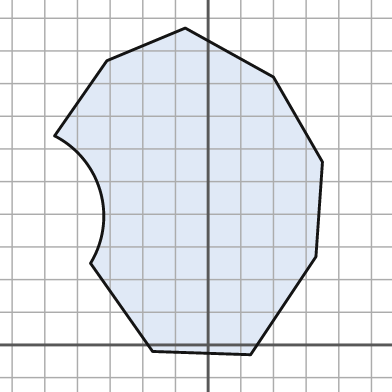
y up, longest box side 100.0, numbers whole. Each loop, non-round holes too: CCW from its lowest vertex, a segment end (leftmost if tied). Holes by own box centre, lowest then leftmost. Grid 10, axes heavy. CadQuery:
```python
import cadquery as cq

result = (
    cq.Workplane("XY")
    .moveTo(13.0, -3.0)
    .lineTo(33.0, 27.0)
    .lineTo(35.0, 56.0)
    .lineTo(20.0, 82.0)
    .lineTo(-7.0, 97.0)
    .lineTo(-31.0, 87.0)
    .lineTo(-47.0, 64.0)
    .threePointArc((-33.0, 47.0), (-36.0, 25.0))
    .lineTo(-17.0, -2.0)
    .close()
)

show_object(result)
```